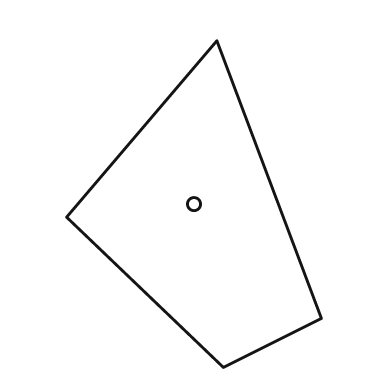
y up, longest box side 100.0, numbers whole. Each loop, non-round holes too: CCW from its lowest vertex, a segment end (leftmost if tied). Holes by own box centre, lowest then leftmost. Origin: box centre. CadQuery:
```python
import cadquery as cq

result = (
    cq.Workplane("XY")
    .moveTo(9.0, -50.0)
    .lineTo(39.0, -35.0)
    .lineTo(7.0, 50.0)
    .lineTo(-39.0, -4.0)
    .close()
    .moveTo(0.0, 0.0)
    .circle(2.0)
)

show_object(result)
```